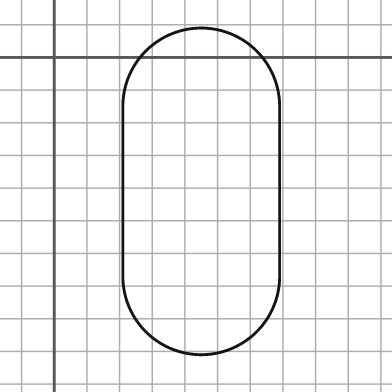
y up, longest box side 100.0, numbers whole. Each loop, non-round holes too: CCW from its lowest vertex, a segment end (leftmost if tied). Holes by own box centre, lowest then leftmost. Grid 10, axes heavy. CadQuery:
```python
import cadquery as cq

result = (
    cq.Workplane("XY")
    .moveTo(21.0, -67.0)
    .threePointArc((45.0, -91.0), (69.0, -67.0))
    .lineTo(69.0, -15.0)
    .threePointArc((45.0, 9.0), (21.0, -15.0))
    .close()
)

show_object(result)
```